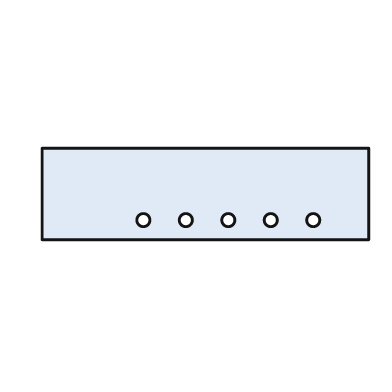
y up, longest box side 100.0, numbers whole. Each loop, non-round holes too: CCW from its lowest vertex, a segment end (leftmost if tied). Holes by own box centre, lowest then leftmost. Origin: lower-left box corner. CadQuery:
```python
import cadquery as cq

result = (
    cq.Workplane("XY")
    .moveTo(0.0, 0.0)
    .lineTo(100.0, 0.0)
    .lineTo(100.0, 28.0)
    .lineTo(0.0, 28.0)
    .close()
    .moveTo(31.0, 6.0)
    .circle(2.0)
    .moveTo(44.0, 6.0)
    .circle(2.0)
    .moveTo(57.0, 6.0)
    .circle(2.0)
    .moveTo(70.0, 6.0)
    .circle(2.0)
    .moveTo(83.0, 6.0)
    .circle(2.0)
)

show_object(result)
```